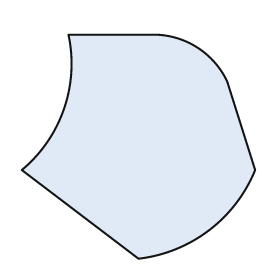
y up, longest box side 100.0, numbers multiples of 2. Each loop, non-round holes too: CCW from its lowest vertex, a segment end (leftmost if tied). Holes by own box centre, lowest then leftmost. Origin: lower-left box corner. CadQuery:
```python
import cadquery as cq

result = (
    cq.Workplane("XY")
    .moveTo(50.0, 0.0)
    .threePointArc((80.0, 12.0), (100.0, 38.0))
    .lineTo(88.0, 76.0)
    .threePointArc((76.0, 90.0), (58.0, 96.0))
    .lineTo(20.0, 96.0)
    .threePointArc((18.0, 64.0), (0.0, 38.0))
    .close()
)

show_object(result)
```